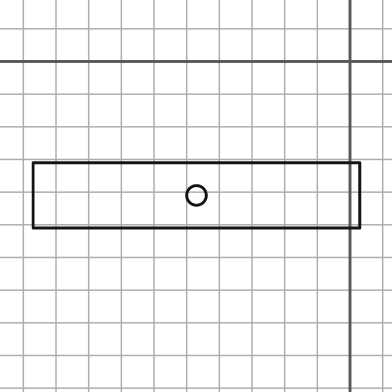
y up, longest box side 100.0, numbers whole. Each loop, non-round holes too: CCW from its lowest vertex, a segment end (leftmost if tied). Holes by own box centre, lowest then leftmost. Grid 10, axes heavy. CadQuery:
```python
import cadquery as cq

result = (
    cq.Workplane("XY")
    .moveTo(-97.0, -51.0)
    .lineTo(3.0, -51.0)
    .lineTo(3.0, -31.0)
    .lineTo(-97.0, -31.0)
    .close()
    .moveTo(-47.0, -41.0)
    .circle(3.0)
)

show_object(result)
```